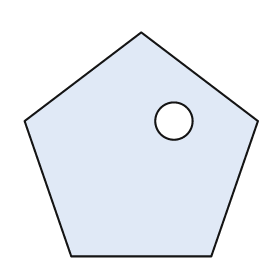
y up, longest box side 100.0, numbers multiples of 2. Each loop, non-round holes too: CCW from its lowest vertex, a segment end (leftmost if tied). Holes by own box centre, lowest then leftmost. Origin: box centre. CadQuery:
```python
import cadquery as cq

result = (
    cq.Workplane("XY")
    .moveTo(-30.0, -48.0)
    .lineTo(30.0, -48.0)
    .lineTo(50.0, 10.0)
    .lineTo(0.0, 48.0)
    .lineTo(-50.0, 10.0)
    .close()
    .moveTo(14.0, 10.0)
    .circle(8.0)
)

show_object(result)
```